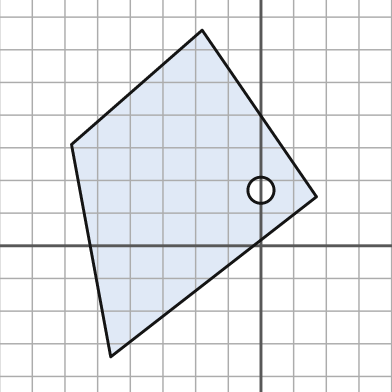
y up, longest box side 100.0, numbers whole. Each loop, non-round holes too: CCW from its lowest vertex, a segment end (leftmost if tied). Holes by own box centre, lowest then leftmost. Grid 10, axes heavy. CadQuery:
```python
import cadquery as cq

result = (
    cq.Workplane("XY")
    .moveTo(-46.0, -34.0)
    .lineTo(17.0, 15.0)
    .lineTo(-18.0, 66.0)
    .lineTo(-58.0, 31.0)
    .close()
    .moveTo(0.0, 17.0)
    .circle(4.0)
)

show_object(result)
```